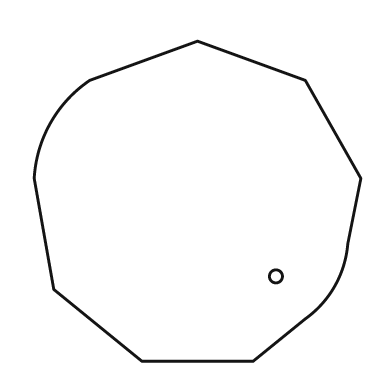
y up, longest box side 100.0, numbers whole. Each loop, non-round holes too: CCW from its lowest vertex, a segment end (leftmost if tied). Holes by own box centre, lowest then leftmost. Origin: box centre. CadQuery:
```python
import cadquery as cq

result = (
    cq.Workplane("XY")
    .moveTo(-17.0, -49.0)
    .lineTo(17.0, -49.0)
    .lineTo(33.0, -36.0)
    .threePointArc((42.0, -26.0), (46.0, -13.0))
    .lineTo(50.0, 7.0)
    .lineTo(33.0, 37.0)
    .lineTo(0.0, 49.0)
    .lineTo(-33.0, 37.0)
    .threePointArc((-45.0, 24.0), (-50.0, 7.0))
    .lineTo(-44.0, -27.0)
    .close()
    .moveTo(24.0, -23.0)
    .circle(2.0)
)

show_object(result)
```